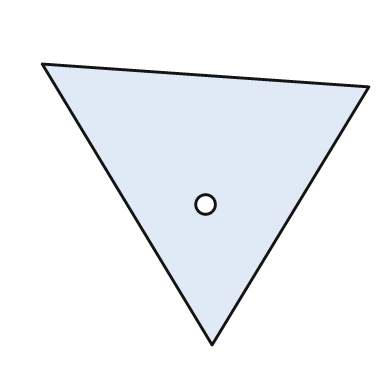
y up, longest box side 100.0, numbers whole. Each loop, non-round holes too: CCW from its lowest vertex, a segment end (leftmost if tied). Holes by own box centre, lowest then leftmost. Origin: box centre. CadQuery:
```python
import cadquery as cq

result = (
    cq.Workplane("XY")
    .moveTo(2.0, -43.0)
    .lineTo(50.0, 36.0)
    .lineTo(-50.0, 43.0)
    .close()
    .moveTo(0.0, 0.0)
    .circle(3.0)
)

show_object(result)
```